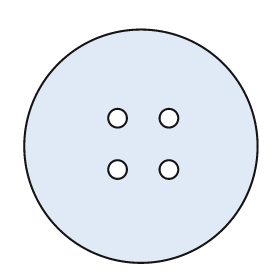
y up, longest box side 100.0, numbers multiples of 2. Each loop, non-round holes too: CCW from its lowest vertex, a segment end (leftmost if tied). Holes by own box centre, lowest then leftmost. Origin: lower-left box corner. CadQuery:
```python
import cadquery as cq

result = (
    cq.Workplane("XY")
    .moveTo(50.0, 50.0)
    .circle(50.0)
    .moveTo(40.0, 40.0)
    .circle(4.0)
    .moveTo(62.0, 40.0)
    .circle(4.0)
    .moveTo(40.0, 62.0)
    .circle(4.0)
    .moveTo(62.0, 62.0)
    .circle(4.0)
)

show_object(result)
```